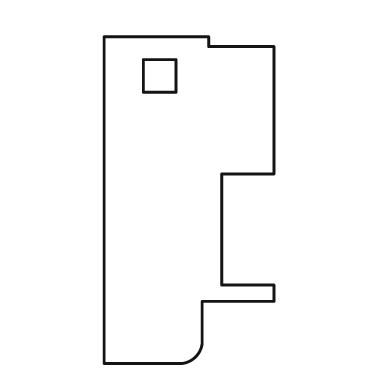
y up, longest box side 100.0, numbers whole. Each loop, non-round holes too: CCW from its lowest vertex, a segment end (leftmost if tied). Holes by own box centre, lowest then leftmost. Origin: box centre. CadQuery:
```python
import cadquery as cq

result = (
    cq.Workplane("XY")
    .moveTo(-26.0, -50.0)
    .lineTo(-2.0, -50.0)
    .threePointArc((2.0, -48.0), (4.0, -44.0))
    .lineTo(4.0, -31.0)
    .lineTo(26.0, -31.0)
    .lineTo(26.0, -26.0)
    .lineTo(10.0, -26.0)
    .lineTo(10.0, 8.0)
    .lineTo(26.0, 8.0)
    .lineTo(26.0, 47.0)
    .lineTo(6.0, 47.0)
    .lineTo(6.0, 50.0)
    .lineTo(-26.0, 50.0)
    .close()
    .moveTo(-14.0, 33.0)
    .lineTo(-4.0, 33.0)
    .lineTo(-4.0, 43.0)
    .lineTo(-14.0, 43.0)
    .close()
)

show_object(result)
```